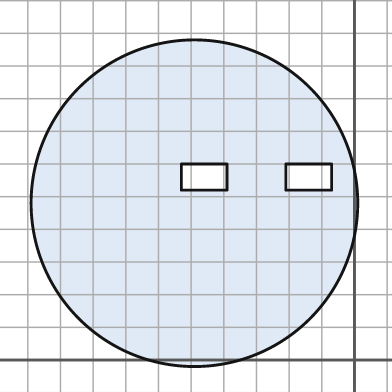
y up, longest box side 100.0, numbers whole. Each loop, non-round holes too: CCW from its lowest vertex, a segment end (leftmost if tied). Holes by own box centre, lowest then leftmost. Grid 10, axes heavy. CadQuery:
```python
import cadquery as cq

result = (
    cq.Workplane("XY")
    .moveTo(-49.0, 48.0)
    .circle(50.0)
    .moveTo(-53.0, 52.0)
    .lineTo(-39.0, 52.0)
    .lineTo(-39.0, 60.0)
    .lineTo(-53.0, 60.0)
    .close()
    .moveTo(-21.0, 52.0)
    .lineTo(-7.0, 52.0)
    .lineTo(-7.0, 60.0)
    .lineTo(-21.0, 60.0)
    .close()
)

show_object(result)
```